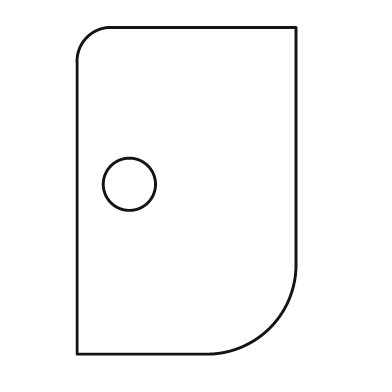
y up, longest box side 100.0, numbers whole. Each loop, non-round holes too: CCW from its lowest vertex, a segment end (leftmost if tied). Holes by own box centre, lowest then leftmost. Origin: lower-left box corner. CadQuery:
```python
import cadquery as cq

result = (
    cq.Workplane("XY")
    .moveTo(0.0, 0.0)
    .lineTo(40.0, 0.0)
    .threePointArc((59.0, 8.0), (67.0, 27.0))
    .lineTo(67.0, 100.0)
    .lineTo(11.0, 100.0)
    .threePointArc((3.0, 97.0), (0.0, 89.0))
    .close()
    .moveTo(16.0, 52.0)
    .circle(8.0)
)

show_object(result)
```